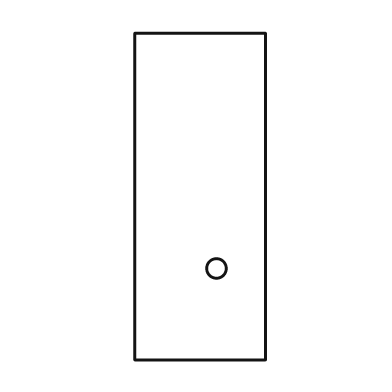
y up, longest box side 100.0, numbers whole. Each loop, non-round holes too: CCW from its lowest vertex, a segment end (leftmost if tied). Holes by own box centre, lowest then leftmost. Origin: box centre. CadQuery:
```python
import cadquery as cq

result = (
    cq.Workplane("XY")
    .moveTo(-20.0, -50.0)
    .lineTo(20.0, -50.0)
    .lineTo(20.0, 50.0)
    .lineTo(-20.0, 50.0)
    .close()
    .moveTo(5.0, -22.0)
    .circle(3.0)
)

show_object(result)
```